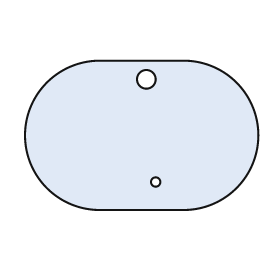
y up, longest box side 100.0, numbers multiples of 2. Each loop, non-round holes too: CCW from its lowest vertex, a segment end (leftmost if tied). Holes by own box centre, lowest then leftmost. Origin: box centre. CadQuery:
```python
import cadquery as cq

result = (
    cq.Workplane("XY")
    .moveTo(-18.0, -32.0)
    .lineTo(18.0, -32.0)
    .threePointArc((50.0, 0.0), (18.0, 32.0))
    .lineTo(-18.0, 32.0)
    .threePointArc((-50.0, 0.0), (-18.0, -32.0))
    .close()
    .moveTo(6.0, -20.0)
    .circle(2.0)
    .moveTo(2.0, 24.0)
    .circle(4.0)
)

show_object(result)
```